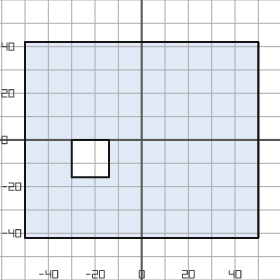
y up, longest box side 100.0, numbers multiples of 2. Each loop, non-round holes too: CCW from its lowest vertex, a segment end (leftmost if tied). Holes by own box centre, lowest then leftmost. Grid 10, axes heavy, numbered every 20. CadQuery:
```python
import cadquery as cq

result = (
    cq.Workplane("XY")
    .moveTo(-50.0, -42.0)
    .lineTo(50.0, -42.0)
    .lineTo(50.0, 42.0)
    .lineTo(-50.0, 42.0)
    .close()
    .moveTo(-30.0, -16.0)
    .lineTo(-14.0, -16.0)
    .lineTo(-14.0, 0.0)
    .lineTo(-30.0, 0.0)
    .close()
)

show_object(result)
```